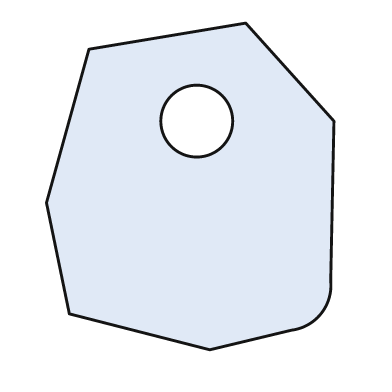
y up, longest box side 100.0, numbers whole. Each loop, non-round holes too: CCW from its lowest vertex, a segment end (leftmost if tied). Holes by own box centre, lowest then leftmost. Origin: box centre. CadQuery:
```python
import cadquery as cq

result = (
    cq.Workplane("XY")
    .moveTo(6.0, -50.0)
    .lineTo(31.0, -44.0)
    .threePointArc((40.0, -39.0), (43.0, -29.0))
    .lineTo(44.0, 20.0)
    .lineTo(17.0, 50.0)
    .lineTo(-31.0, 42.0)
    .lineTo(-44.0, -5.0)
    .lineTo(-37.0, -39.0)
    .close()
    .moveTo(2.0, 20.0)
    .circle(11.0)
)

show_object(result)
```